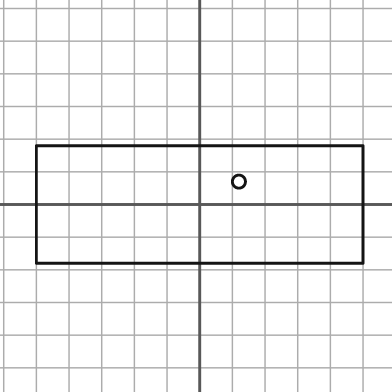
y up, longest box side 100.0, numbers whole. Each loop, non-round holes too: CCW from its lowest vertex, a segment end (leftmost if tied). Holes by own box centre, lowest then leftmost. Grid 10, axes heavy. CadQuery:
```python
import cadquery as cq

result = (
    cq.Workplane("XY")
    .moveTo(-50.0, -18.0)
    .lineTo(50.0, -18.0)
    .lineTo(50.0, 18.0)
    .lineTo(-50.0, 18.0)
    .close()
    .moveTo(12.0, 7.0)
    .circle(2.0)
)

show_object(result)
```